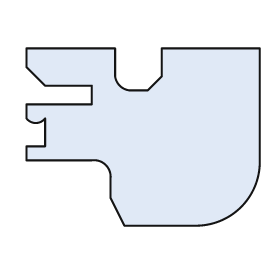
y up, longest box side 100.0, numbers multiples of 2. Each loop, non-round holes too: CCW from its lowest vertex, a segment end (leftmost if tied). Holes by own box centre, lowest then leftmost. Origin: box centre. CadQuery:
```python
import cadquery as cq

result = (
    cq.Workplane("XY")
    .moveTo(-8.0, -38.0)
    .lineTo(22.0, -38.0)
    .threePointArc((42.0, -30.0), (50.0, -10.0))
    .lineTo(50.0, 38.0)
    .lineTo(8.0, 38.0)
    .lineTo(8.0, 26.0)
    .lineTo(2.0, 20.0)
    .lineTo(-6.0, 20.0)
    .threePointArc((-10.0, 22.0), (-12.0, 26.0))
    .lineTo(-12.0, 38.0)
    .lineTo(-50.0, 38.0)
    .lineTo(-50.0, 30.0)
    .lineTo(-42.0, 22.0)
    .lineTo(-22.0, 22.0)
    .lineTo(-22.0, 14.0)
    .lineTo(-50.0, 14.0)
    .lineTo(-50.0, 8.0)
    .threePointArc((-46.0, 6.0), (-42.0, 8.0))
    .lineTo(-42.0, -4.0)
    .lineTo(-50.0, -4.0)
    .lineTo(-50.0, -10.0)
    .lineTo(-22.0, -10.0)
    .threePointArc((-16.0, -12.0), (-14.0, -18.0))
    .lineTo(-14.0, -26.0)
    .close()
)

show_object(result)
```